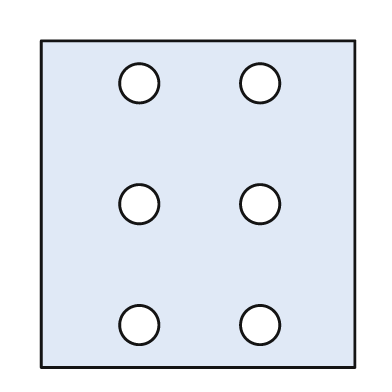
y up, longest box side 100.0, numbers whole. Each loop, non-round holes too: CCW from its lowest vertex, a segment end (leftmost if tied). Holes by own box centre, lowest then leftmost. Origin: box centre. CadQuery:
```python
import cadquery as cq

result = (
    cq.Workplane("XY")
    .moveTo(-48.0, -50.0)
    .lineTo(48.0, -50.0)
    .lineTo(48.0, 50.0)
    .lineTo(-48.0, 50.0)
    .close()
    .moveTo(-18.0, -37.0)
    .circle(6.0)
    .moveTo(19.0, -37.0)
    .circle(6.0)
    .moveTo(-18.0, 0.0)
    .circle(6.0)
    .moveTo(19.0, 0.0)
    .circle(6.0)
    .moveTo(-18.0, 37.0)
    .circle(6.0)
    .moveTo(19.0, 37.0)
    .circle(6.0)
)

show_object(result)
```